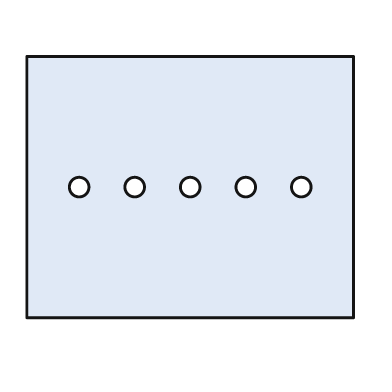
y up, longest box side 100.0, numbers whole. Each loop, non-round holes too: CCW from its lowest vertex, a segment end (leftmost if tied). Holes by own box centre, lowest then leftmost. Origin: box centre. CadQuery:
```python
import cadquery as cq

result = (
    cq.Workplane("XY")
    .moveTo(-50.0, -40.0)
    .lineTo(50.0, -40.0)
    .lineTo(50.0, 40.0)
    .lineTo(-50.0, 40.0)
    .close()
    .moveTo(-34.0, 0.0)
    .circle(3.0)
    .moveTo(-17.0, 0.0)
    .circle(3.0)
    .moveTo(0.0, 0.0)
    .circle(3.0)
    .moveTo(17.0, 0.0)
    .circle(3.0)
    .moveTo(34.0, 0.0)
    .circle(3.0)
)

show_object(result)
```